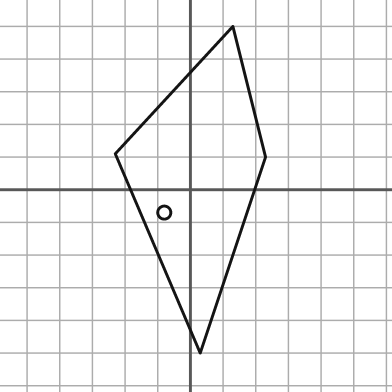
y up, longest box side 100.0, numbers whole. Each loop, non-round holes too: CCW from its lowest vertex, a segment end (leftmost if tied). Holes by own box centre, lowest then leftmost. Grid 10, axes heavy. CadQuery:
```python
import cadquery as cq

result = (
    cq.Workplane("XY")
    .moveTo(3.0, -50.0)
    .lineTo(23.0, 10.0)
    .lineTo(13.0, 50.0)
    .lineTo(-23.0, 11.0)
    .close()
    .moveTo(-8.0, -7.0)
    .circle(2.0)
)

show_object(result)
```